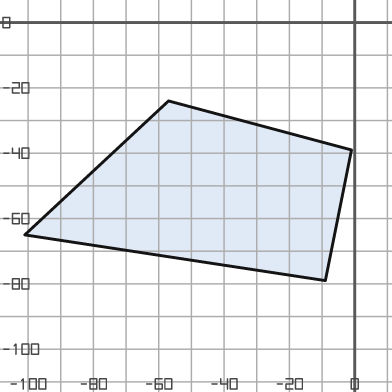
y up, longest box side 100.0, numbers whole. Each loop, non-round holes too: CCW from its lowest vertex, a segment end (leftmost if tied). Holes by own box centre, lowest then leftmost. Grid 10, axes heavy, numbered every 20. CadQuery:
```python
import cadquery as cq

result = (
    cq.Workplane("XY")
    .moveTo(-9.0, -79.0)
    .lineTo(-1.0, -39.0)
    .lineTo(-57.0, -24.0)
    .lineTo(-101.0, -65.0)
    .close()
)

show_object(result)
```